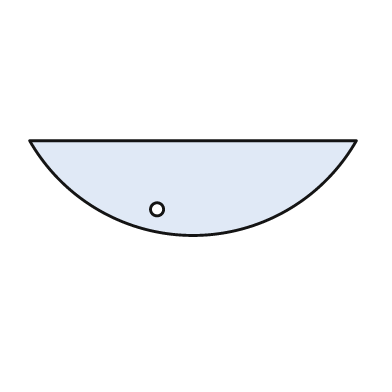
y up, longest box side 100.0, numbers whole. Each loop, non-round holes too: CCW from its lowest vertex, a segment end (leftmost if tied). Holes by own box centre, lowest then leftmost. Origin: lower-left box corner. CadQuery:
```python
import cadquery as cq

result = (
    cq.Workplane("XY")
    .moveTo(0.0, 29.0)
    .threePointArc((50.0, 0.0), (100.0, 29.0))
    .close()
    .moveTo(39.0, 8.0)
    .circle(2.0)
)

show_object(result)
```